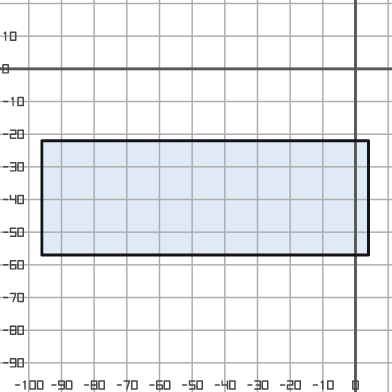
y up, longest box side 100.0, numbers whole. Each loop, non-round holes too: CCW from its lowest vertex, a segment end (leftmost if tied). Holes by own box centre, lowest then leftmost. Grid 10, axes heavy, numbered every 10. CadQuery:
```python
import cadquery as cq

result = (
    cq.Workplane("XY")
    .moveTo(-96.0, -57.0)
    .lineTo(4.0, -57.0)
    .lineTo(4.0, -22.0)
    .lineTo(-96.0, -22.0)
    .close()
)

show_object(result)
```